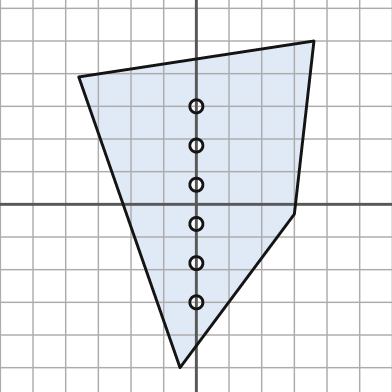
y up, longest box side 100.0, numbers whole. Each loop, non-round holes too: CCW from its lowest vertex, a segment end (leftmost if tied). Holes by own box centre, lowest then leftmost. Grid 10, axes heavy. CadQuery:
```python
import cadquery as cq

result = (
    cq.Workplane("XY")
    .moveTo(-5.0, -50.0)
    .lineTo(30.0, -3.0)
    .lineTo(36.0, 50.0)
    .lineTo(-36.0, 39.0)
    .close()
    .moveTo(0.0, -30.0)
    .circle(2.0)
    .moveTo(0.0, -18.0)
    .circle(2.0)
    .moveTo(0.0, -6.0)
    .circle(2.0)
    .moveTo(0.0, 6.0)
    .circle(2.0)
    .moveTo(0.0, 18.0)
    .circle(2.0)
    .moveTo(0.0, 30.0)
    .circle(2.0)
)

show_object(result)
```